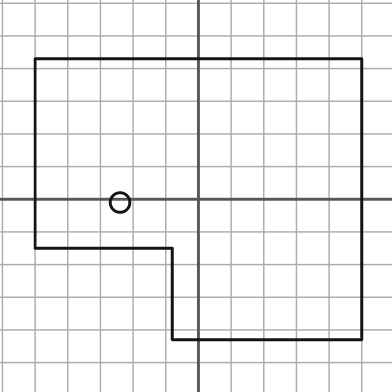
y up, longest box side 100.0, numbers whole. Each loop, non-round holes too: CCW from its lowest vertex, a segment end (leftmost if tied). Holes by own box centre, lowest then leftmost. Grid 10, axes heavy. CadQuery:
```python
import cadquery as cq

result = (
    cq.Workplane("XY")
    .moveTo(-8.0, -43.0)
    .lineTo(50.0, -43.0)
    .lineTo(50.0, 43.0)
    .lineTo(-50.0, 43.0)
    .lineTo(-50.0, -15.0)
    .lineTo(-8.0, -15.0)
    .close()
    .moveTo(-24.0, -1.0)
    .circle(3.0)
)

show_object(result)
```